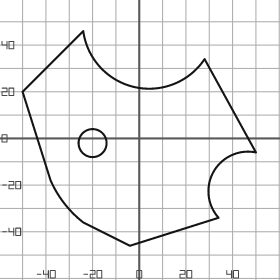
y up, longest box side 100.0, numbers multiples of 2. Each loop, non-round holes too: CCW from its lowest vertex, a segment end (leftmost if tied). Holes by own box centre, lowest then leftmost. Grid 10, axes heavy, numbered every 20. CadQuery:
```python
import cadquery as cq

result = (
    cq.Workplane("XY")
    .moveTo(-4.0, -46.0)
    .lineTo(34.0, -34.0)
    .threePointArc((32.0, -14.0), (50.0, -6.0))
    .lineTo(28.0, 34.0)
    .threePointArc((-2.0, 22.0), (-24.0, 46.0))
    .lineTo(-50.0, 20.0)
    .lineTo(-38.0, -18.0)
    .threePointArc((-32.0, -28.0), (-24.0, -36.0))
    .close()
    .moveTo(-20.0, -2.0)
    .circle(6.0)
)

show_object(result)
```